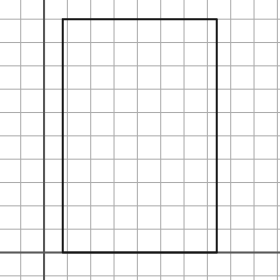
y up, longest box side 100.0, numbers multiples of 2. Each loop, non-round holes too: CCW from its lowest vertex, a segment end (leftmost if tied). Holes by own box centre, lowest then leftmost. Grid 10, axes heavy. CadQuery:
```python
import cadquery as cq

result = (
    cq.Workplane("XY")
    .moveTo(8.0, 0.0)
    .lineTo(74.0, 0.0)
    .lineTo(74.0, 100.0)
    .lineTo(8.0, 100.0)
    .close()
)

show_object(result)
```